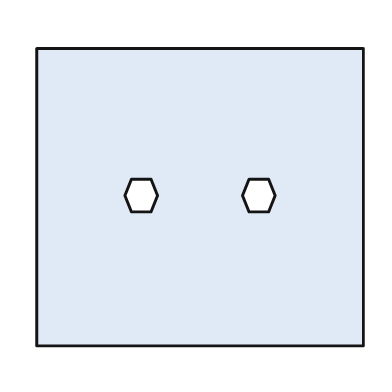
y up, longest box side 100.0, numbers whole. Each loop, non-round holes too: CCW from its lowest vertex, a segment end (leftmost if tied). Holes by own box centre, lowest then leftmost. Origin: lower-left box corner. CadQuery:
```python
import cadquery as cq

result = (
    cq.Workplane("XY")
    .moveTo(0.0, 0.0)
    .lineTo(100.0, 0.0)
    .lineTo(100.0, 91.0)
    .lineTo(0.0, 91.0)
    .close()
    .moveTo(29.0, 41.0)
    .lineTo(35.0, 41.0)
    .lineTo(37.0, 46.0)
    .lineTo(35.0, 51.0)
    .lineTo(29.0, 51.0)
    .lineTo(27.0, 46.0)
    .close()
    .moveTo(65.0, 41.0)
    .lineTo(71.0, 41.0)
    .lineTo(73.0, 46.0)
    .lineTo(71.0, 51.0)
    .lineTo(65.0, 51.0)
    .lineTo(63.0, 46.0)
    .close()
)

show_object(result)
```